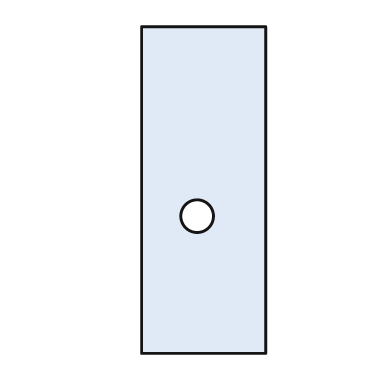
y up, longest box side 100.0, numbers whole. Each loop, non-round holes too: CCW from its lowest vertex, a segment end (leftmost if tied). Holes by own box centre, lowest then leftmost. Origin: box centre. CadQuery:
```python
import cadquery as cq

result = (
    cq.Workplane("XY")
    .moveTo(-19.0, -50.0)
    .lineTo(19.0, -50.0)
    .lineTo(19.0, 50.0)
    .lineTo(-19.0, 50.0)
    .close()
    .moveTo(-2.0, -8.0)
    .circle(5.0)
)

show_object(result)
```